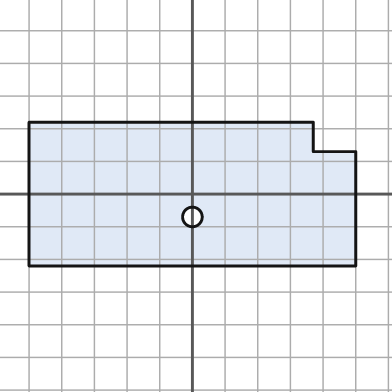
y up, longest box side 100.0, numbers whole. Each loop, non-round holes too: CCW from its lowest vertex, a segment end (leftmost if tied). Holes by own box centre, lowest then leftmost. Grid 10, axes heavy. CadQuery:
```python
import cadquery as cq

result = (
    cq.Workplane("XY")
    .moveTo(-50.0, -22.0)
    .lineTo(50.0, -22.0)
    .lineTo(50.0, 13.0)
    .lineTo(37.0, 13.0)
    .lineTo(37.0, 22.0)
    .lineTo(-50.0, 22.0)
    .close()
    .moveTo(0.0, -7.0)
    .circle(3.0)
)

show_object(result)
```